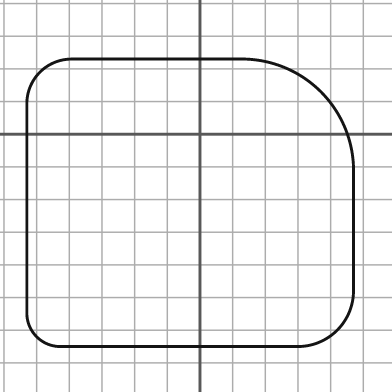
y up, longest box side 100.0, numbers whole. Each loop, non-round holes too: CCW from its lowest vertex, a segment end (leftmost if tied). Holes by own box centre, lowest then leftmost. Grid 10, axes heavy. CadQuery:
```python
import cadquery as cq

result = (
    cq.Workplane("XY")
    .moveTo(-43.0, -65.0)
    .lineTo(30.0, -65.0)
    .threePointArc((42.0, -60.0), (47.0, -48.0))
    .lineTo(47.0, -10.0)
    .threePointArc((37.0, 13.0), (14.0, 23.0))
    .lineTo(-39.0, 23.0)
    .threePointArc((-49.0, 19.0), (-53.0, 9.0))
    .lineTo(-53.0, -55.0)
    .threePointArc((-50.0, -62.0), (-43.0, -65.0))
    .close()
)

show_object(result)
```